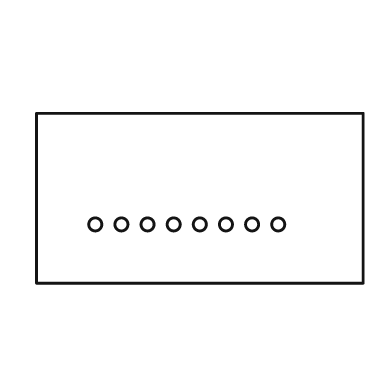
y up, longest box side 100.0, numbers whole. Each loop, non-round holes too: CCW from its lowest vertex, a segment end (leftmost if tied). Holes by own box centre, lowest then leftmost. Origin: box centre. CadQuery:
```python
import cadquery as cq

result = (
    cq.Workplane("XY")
    .moveTo(-50.0, -26.0)
    .lineTo(50.0, -26.0)
    .lineTo(50.0, 26.0)
    .lineTo(-50.0, 26.0)
    .close()
    .moveTo(-32.0, -8.0)
    .circle(2.0)
    .moveTo(-24.0, -8.0)
    .circle(2.0)
    .moveTo(-16.0, -8.0)
    .circle(2.0)
    .moveTo(-8.0, -8.0)
    .circle(2.0)
    .moveTo(0.0, -8.0)
    .circle(2.0)
    .moveTo(8.0, -8.0)
    .circle(2.0)
    .moveTo(16.0, -8.0)
    .circle(2.0)
    .moveTo(24.0, -8.0)
    .circle(2.0)
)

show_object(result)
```